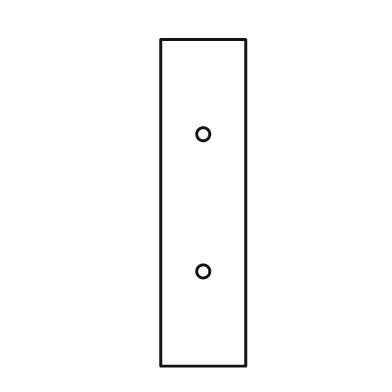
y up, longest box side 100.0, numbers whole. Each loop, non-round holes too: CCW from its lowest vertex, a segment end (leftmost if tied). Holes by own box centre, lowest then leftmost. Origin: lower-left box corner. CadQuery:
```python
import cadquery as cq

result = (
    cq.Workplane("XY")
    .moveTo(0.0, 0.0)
    .lineTo(26.0, 0.0)
    .lineTo(26.0, 100.0)
    .lineTo(0.0, 100.0)
    .close()
    .moveTo(13.0, 29.0)
    .circle(2.0)
    .moveTo(13.0, 71.0)
    .circle(2.0)
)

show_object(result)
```